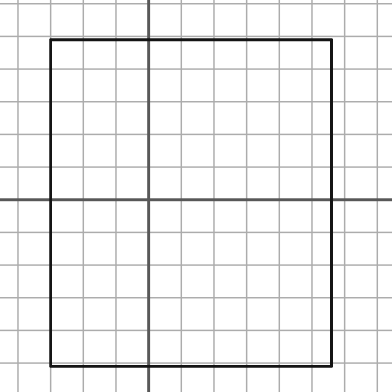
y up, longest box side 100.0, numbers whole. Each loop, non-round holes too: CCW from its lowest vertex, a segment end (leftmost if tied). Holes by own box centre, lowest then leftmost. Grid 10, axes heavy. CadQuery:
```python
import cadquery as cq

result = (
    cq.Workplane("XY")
    .moveTo(-30.0, -51.0)
    .lineTo(56.0, -51.0)
    .lineTo(56.0, 49.0)
    .lineTo(-30.0, 49.0)
    .close()
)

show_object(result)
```